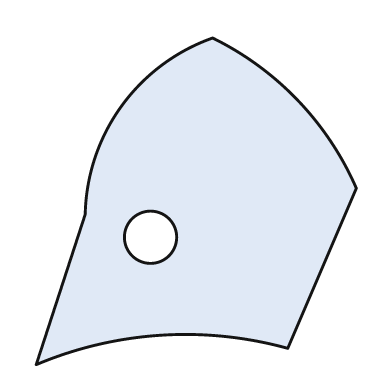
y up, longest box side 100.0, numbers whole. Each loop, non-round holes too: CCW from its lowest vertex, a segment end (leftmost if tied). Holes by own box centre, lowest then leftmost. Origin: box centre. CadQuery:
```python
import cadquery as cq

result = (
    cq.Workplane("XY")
    .moveTo(-49.0, -50.0)
    .threePointArc((-11.0, -41.0), (28.0, -45.0))
    .lineTo(49.0, 4.0)
    .threePointArc((31.0, 31.0), (5.0, 50.0))
    .threePointArc((-23.0, 29.0), (-34.0, -4.0))
    .close()
    .moveTo(-14.0, -11.0)
    .circle(8.0)
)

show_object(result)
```